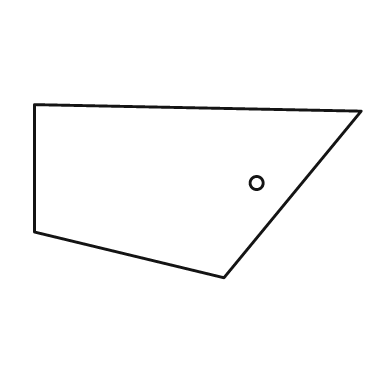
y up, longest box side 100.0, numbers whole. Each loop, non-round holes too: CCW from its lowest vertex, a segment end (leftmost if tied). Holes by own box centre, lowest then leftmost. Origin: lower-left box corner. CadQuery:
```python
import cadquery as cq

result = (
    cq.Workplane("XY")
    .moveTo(58.0, 0.0)
    .lineTo(100.0, 51.0)
    .lineTo(0.0, 53.0)
    .lineTo(0.0, 14.0)
    .close()
    .moveTo(68.0, 29.0)
    .circle(2.0)
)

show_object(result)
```